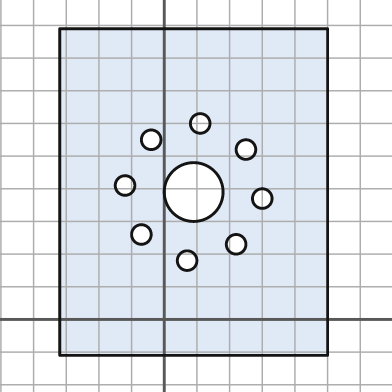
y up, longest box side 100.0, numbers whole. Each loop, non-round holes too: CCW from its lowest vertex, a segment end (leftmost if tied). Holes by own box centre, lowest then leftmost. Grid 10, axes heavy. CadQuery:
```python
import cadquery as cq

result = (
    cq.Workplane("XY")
    .moveTo(-32.0, -11.0)
    .lineTo(50.0, -11.0)
    .lineTo(50.0, 89.0)
    .lineTo(-32.0, 89.0)
    .close()
    .moveTo(7.0, 18.0)
    .circle(3.0)
    .moveTo(22.0, 23.0)
    .circle(3.0)
    .moveTo(-7.0, 26.0)
    .circle(3.0)
    .moveTo(30.0, 37.0)
    .circle(3.0)
    .moveTo(9.0, 39.0)
    .circle(9.0)
    .moveTo(-12.0, 41.0)
    .circle(3.0)
    .moveTo(25.0, 52.0)
    .circle(3.0)
    .moveTo(-4.0, 55.0)
    .circle(3.0)
    .moveTo(11.0, 60.0)
    .circle(3.0)
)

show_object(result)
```